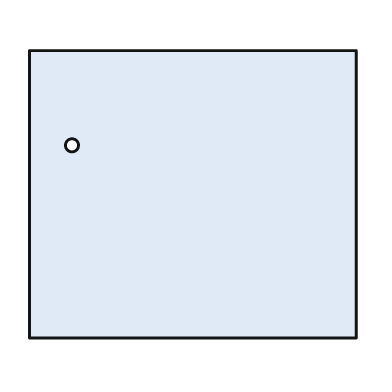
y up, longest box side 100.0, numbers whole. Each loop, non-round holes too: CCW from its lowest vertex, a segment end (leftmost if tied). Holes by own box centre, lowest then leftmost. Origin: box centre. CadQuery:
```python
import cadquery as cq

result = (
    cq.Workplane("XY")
    .moveTo(-50.0, -44.0)
    .lineTo(50.0, -44.0)
    .lineTo(50.0, 44.0)
    .lineTo(-50.0, 44.0)
    .close()
    .moveTo(-37.0, 15.0)
    .circle(2.0)
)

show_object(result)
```